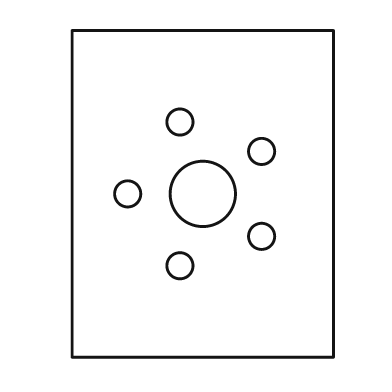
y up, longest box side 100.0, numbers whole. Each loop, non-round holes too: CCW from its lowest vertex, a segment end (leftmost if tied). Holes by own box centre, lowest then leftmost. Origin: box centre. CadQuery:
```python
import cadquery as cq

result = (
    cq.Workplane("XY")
    .moveTo(-40.0, -50.0)
    .lineTo(40.0, -50.0)
    .lineTo(40.0, 50.0)
    .lineTo(-40.0, 50.0)
    .close()
    .moveTo(-7.0, -22.0)
    .circle(4.0)
    .moveTo(18.0, -13.0)
    .circle(4.0)
    .moveTo(-23.0, 0.0)
    .circle(4.0)
    .moveTo(0.0, 0.0)
    .circle(10.0)
    .moveTo(18.0, 13.0)
    .circle(4.0)
    .moveTo(-7.0, 22.0)
    .circle(4.0)
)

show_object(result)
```